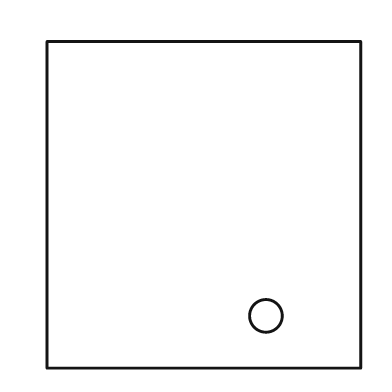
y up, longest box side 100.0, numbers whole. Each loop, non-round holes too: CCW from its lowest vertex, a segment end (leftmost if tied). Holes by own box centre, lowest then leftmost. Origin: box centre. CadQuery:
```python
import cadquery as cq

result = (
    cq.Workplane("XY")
    .moveTo(-48.0, -50.0)
    .lineTo(48.0, -50.0)
    .lineTo(48.0, 50.0)
    .lineTo(-48.0, 50.0)
    .close()
    .moveTo(19.0, -34.0)
    .circle(5.0)
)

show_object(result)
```